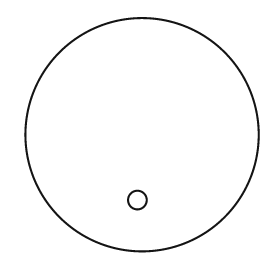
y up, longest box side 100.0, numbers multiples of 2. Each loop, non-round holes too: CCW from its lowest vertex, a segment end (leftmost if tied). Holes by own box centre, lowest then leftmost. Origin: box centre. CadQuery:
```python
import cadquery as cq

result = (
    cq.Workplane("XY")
    .moveTo(0.0, 0.0)
    .circle(50.0)
    .moveTo(-2.0, -28.0)
    .circle(4.0)
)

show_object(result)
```